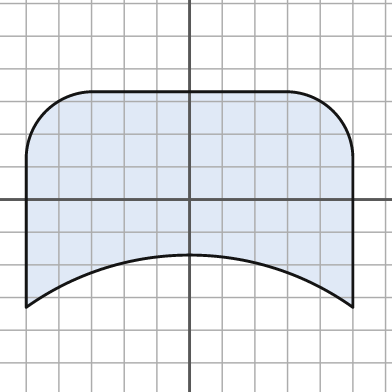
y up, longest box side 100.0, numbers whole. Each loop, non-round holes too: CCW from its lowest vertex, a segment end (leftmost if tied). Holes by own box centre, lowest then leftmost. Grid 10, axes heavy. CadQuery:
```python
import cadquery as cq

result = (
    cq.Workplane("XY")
    .moveTo(-50.0, -33.0)
    .threePointArc((0.0, -17.0), (50.0, -33.0))
    .lineTo(50.0, 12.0)
    .threePointArc((44.0, 27.0), (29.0, 33.0))
    .lineTo(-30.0, 33.0)
    .threePointArc((-44.0, 27.0), (-50.0, 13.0))
    .close()
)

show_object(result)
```